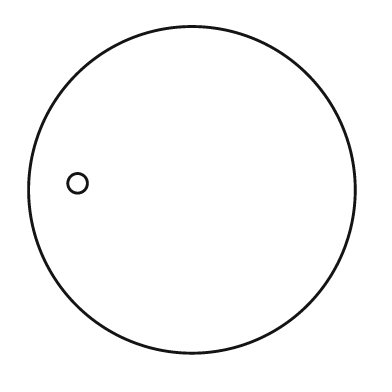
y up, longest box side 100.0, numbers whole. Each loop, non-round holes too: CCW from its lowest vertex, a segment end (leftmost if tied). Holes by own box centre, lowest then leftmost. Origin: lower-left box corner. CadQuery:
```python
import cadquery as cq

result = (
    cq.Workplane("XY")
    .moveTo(50.0, 50.0)
    .circle(50.0)
    .moveTo(15.0, 52.0)
    .circle(3.0)
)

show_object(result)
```